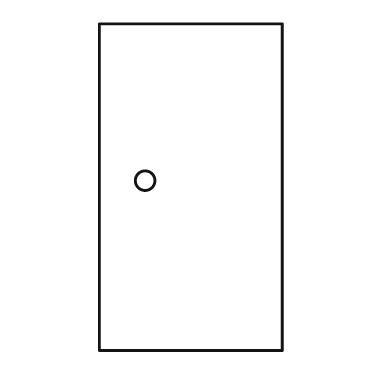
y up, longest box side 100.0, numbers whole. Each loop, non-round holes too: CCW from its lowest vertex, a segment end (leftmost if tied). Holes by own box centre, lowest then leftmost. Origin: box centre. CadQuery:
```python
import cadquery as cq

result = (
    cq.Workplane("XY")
    .moveTo(-28.0, -50.0)
    .lineTo(28.0, -50.0)
    .lineTo(28.0, 50.0)
    .lineTo(-28.0, 50.0)
    .close()
    .moveTo(-14.0, 2.0)
    .circle(3.0)
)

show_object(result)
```